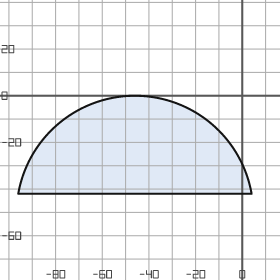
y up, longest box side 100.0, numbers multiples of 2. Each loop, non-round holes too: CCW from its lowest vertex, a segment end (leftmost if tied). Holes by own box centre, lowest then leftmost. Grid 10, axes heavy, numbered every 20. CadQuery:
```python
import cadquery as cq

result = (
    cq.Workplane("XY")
    .moveTo(-96.0, -42.0)
    .lineTo(4.0, -42.0)
    .threePointArc((-46.0, 0.0), (-96.0, -42.0))
    .close()
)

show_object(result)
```